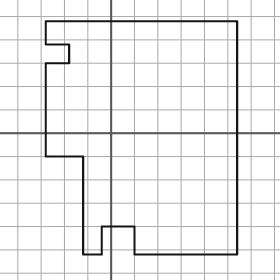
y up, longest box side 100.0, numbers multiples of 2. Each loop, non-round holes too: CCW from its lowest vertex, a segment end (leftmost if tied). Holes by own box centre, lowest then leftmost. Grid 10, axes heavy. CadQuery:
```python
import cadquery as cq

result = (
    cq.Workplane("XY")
    .moveTo(-12.0, -52.0)
    .lineTo(-4.0, -52.0)
    .lineTo(-4.0, -40.0)
    .lineTo(10.0, -40.0)
    .lineTo(10.0, -52.0)
    .lineTo(54.0, -52.0)
    .lineTo(54.0, 48.0)
    .lineTo(-28.0, 48.0)
    .lineTo(-28.0, 38.0)
    .lineTo(-18.0, 38.0)
    .lineTo(-18.0, 30.0)
    .lineTo(-28.0, 30.0)
    .lineTo(-28.0, -10.0)
    .lineTo(-12.0, -10.0)
    .close()
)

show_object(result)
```